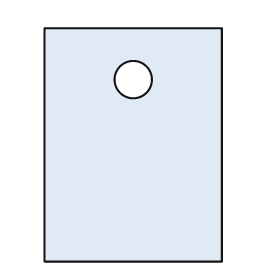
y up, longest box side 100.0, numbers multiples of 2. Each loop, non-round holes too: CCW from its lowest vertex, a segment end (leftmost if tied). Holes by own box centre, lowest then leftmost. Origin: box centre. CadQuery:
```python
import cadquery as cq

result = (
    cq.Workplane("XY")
    .moveTo(-38.0, -50.0)
    .lineTo(38.0, -50.0)
    .lineTo(38.0, 50.0)
    .lineTo(-38.0, 50.0)
    .close()
    .moveTo(0.0, 28.0)
    .circle(8.0)
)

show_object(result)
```